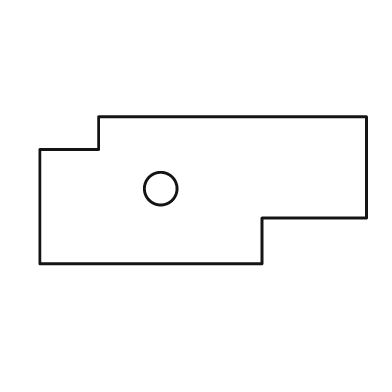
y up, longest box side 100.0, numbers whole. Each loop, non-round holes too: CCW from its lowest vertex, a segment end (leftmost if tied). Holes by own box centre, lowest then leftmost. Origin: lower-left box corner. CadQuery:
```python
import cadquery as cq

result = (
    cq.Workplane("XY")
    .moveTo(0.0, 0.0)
    .lineTo(68.0, 0.0)
    .lineTo(68.0, 14.0)
    .lineTo(100.0, 14.0)
    .lineTo(100.0, 45.0)
    .lineTo(18.0, 45.0)
    .lineTo(18.0, 35.0)
    .lineTo(0.0, 35.0)
    .close()
    .moveTo(37.0, 23.0)
    .circle(5.0)
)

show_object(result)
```